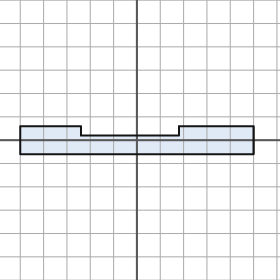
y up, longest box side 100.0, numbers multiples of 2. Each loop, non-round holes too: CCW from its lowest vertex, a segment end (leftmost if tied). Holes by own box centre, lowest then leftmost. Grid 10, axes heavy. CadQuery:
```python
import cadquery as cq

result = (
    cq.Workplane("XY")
    .moveTo(-50.0, -6.0)
    .lineTo(50.0, -6.0)
    .lineTo(50.0, 6.0)
    .lineTo(18.0, 6.0)
    .lineTo(18.0, 2.0)
    .lineTo(-24.0, 2.0)
    .lineTo(-24.0, 6.0)
    .lineTo(-50.0, 6.0)
    .close()
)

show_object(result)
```